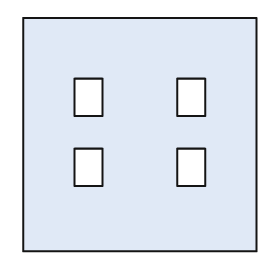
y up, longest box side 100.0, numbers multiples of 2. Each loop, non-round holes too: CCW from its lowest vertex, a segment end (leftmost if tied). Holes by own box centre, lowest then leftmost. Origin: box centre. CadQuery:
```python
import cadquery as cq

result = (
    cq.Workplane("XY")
    .moveTo(-50.0, -50.0)
    .lineTo(50.0, -50.0)
    .lineTo(50.0, 50.0)
    .lineTo(-50.0, 50.0)
    .close()
    .moveTo(-28.0, -22.0)
    .lineTo(-16.0, -22.0)
    .lineTo(-16.0, -6.0)
    .lineTo(-28.0, -6.0)
    .close()
    .moveTo(16.0, -22.0)
    .lineTo(28.0, -22.0)
    .lineTo(28.0, -6.0)
    .lineTo(16.0, -6.0)
    .close()
    .moveTo(-28.0, 8.0)
    .lineTo(-16.0, 8.0)
    .lineTo(-16.0, 24.0)
    .lineTo(-28.0, 24.0)
    .close()
    .moveTo(16.0, 8.0)
    .lineTo(28.0, 8.0)
    .lineTo(28.0, 24.0)
    .lineTo(16.0, 24.0)
    .close()
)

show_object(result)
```